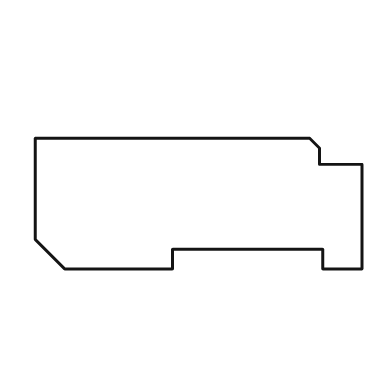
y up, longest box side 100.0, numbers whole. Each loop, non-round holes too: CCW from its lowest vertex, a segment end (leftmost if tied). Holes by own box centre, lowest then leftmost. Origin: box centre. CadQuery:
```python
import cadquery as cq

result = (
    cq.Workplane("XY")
    .moveTo(-41.0, -20.0)
    .lineTo(-8.0, -20.0)
    .lineTo(-8.0, -14.0)
    .lineTo(38.0, -14.0)
    .lineTo(38.0, -20.0)
    .lineTo(50.0, -20.0)
    .lineTo(50.0, 12.0)
    .lineTo(37.0, 12.0)
    .lineTo(37.0, 17.0)
    .lineTo(34.0, 20.0)
    .lineTo(-50.0, 20.0)
    .lineTo(-50.0, -11.0)
    .close()
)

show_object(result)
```